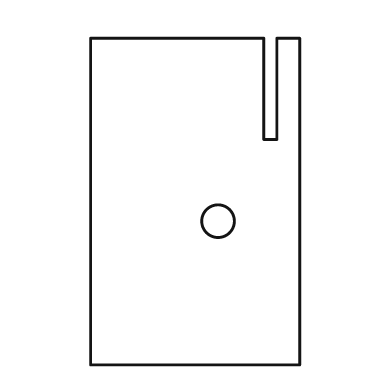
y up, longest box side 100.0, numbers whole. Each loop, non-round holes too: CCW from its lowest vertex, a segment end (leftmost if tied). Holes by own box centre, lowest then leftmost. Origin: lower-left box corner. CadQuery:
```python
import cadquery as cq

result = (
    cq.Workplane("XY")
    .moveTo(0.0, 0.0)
    .lineTo(64.0, 0.0)
    .lineTo(64.0, 100.0)
    .lineTo(57.0, 100.0)
    .lineTo(57.0, 69.0)
    .lineTo(53.0, 69.0)
    .lineTo(53.0, 100.0)
    .lineTo(0.0, 100.0)
    .close()
    .moveTo(39.0, 44.0)
    .circle(5.0)
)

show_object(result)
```